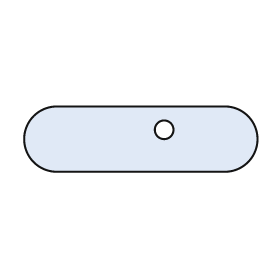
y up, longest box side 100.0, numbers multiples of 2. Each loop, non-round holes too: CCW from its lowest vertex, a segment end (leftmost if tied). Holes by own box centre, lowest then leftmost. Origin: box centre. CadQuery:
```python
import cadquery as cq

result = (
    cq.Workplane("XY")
    .moveTo(-36.0, -14.0)
    .lineTo(36.0, -14.0)
    .threePointArc((50.0, 0.0), (36.0, 14.0))
    .lineTo(-36.0, 14.0)
    .threePointArc((-50.0, 0.0), (-36.0, -14.0))
    .close()
    .moveTo(10.0, 4.0)
    .circle(4.0)
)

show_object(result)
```